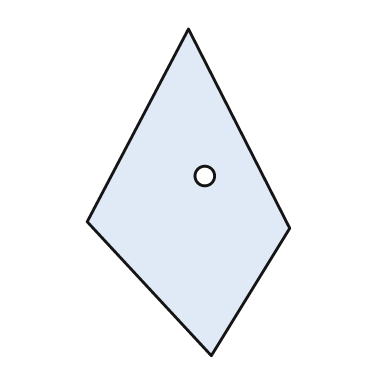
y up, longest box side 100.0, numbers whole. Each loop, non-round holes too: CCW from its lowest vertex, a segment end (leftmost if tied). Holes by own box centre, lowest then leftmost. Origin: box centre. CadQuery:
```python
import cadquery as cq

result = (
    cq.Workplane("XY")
    .moveTo(7.0, -50.0)
    .lineTo(31.0, -11.0)
    .lineTo(0.0, 50.0)
    .lineTo(-31.0, -9.0)
    .close()
    .moveTo(5.0, 5.0)
    .circle(3.0)
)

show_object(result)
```